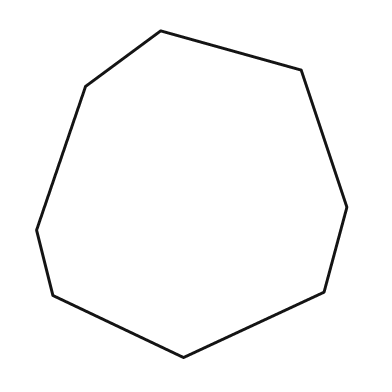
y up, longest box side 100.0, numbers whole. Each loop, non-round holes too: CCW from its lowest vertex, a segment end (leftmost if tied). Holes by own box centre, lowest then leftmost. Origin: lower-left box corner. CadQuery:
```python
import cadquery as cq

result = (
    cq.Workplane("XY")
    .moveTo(45.0, 0.0)
    .lineTo(88.0, 20.0)
    .lineTo(95.0, 46.0)
    .lineTo(81.0, 88.0)
    .lineTo(38.0, 100.0)
    .lineTo(15.0, 83.0)
    .lineTo(0.0, 39.0)
    .lineTo(5.0, 19.0)
    .close()
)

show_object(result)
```